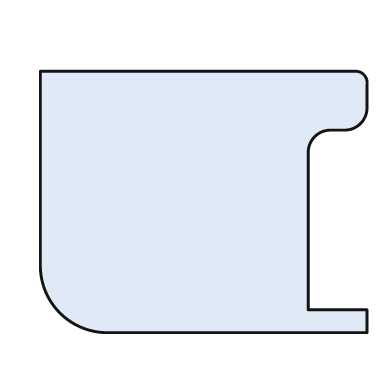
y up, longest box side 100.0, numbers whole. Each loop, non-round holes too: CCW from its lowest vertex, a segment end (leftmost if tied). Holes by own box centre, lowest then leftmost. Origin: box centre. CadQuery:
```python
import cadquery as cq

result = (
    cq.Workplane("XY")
    .moveTo(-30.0, -40.0)
    .lineTo(50.0, -40.0)
    .lineTo(50.0, -33.0)
    .lineTo(32.0, -33.0)
    .lineTo(32.0, 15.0)
    .threePointArc((34.0, 20.0), (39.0, 22.0))
    .lineTo(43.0, 22.0)
    .threePointArc((48.0, 24.0), (50.0, 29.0))
    .lineTo(50.0, 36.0)
    .threePointArc((49.0, 39.0), (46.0, 40.0))
    .lineTo(-50.0, 40.0)
    .lineTo(-50.0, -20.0)
    .threePointArc((-44.0, -34.0), (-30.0, -40.0))
    .close()
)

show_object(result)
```